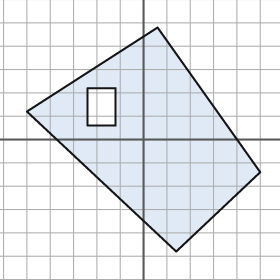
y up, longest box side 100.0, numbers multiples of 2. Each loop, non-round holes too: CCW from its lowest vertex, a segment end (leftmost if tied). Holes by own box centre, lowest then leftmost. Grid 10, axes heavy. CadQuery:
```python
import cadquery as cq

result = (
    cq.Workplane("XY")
    .moveTo(14.0, -48.0)
    .lineTo(50.0, -14.0)
    .lineTo(6.0, 48.0)
    .lineTo(-50.0, 12.0)
    .close()
    .moveTo(-24.0, 6.0)
    .lineTo(-12.0, 6.0)
    .lineTo(-12.0, 22.0)
    .lineTo(-24.0, 22.0)
    .close()
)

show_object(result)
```